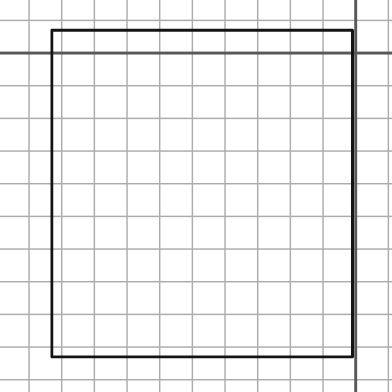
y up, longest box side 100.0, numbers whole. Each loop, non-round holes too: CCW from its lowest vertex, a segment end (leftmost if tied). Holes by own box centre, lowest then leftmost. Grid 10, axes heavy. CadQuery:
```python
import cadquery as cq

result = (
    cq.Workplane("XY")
    .moveTo(-93.0, -93.0)
    .lineTo(-1.0, -93.0)
    .lineTo(-1.0, 7.0)
    .lineTo(-93.0, 7.0)
    .close()
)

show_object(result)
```